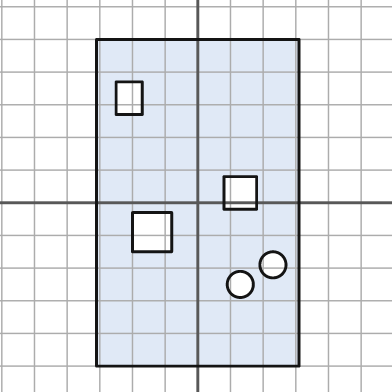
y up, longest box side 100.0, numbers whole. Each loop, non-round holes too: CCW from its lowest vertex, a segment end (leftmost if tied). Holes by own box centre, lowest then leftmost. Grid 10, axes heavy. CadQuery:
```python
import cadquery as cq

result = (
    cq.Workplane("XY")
    .moveTo(-31.0, -50.0)
    .lineTo(31.0, -50.0)
    .lineTo(31.0, 50.0)
    .lineTo(-31.0, 50.0)
    .close()
    .moveTo(13.0, -25.0)
    .circle(4.0)
    .moveTo(23.0, -19.0)
    .circle(4.0)
    .moveTo(-20.0, -15.0)
    .lineTo(-8.0, -15.0)
    .lineTo(-8.0, -3.0)
    .lineTo(-20.0, -3.0)
    .close()
    .moveTo(8.0, -2.0)
    .lineTo(18.0, -2.0)
    .lineTo(18.0, 8.0)
    .lineTo(8.0, 8.0)
    .close()
    .moveTo(-25.0, 27.0)
    .lineTo(-17.0, 27.0)
    .lineTo(-17.0, 37.0)
    .lineTo(-25.0, 37.0)
    .close()
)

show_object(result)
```